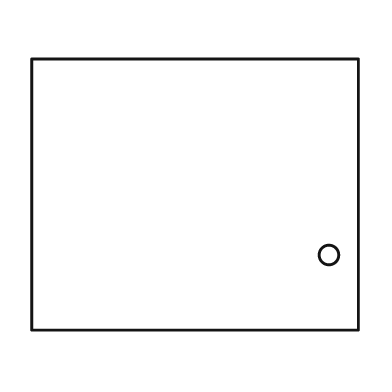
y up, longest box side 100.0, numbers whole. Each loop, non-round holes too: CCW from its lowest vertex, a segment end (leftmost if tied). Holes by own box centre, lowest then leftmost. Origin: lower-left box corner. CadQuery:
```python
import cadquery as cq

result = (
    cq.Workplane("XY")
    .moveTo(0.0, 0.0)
    .lineTo(100.0, 0.0)
    .lineTo(100.0, 83.0)
    .lineTo(0.0, 83.0)
    .close()
    .moveTo(91.0, 23.0)
    .circle(3.0)
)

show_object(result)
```